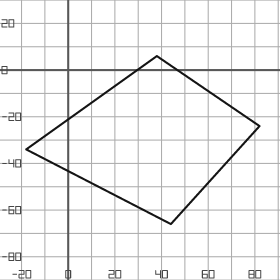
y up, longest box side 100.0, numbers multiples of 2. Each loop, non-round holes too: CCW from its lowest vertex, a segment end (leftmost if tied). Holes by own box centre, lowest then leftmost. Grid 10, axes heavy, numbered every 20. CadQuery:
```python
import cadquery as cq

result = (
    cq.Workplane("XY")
    .moveTo(44.0, -66.0)
    .lineTo(82.0, -24.0)
    .lineTo(38.0, 6.0)
    .lineTo(-18.0, -34.0)
    .close()
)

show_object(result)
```